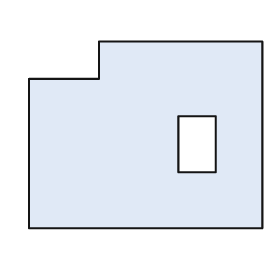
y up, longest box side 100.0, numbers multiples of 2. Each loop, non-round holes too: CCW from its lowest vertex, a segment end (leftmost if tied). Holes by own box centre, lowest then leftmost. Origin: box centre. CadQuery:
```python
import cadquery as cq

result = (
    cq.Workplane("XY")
    .moveTo(-50.0, -40.0)
    .lineTo(50.0, -40.0)
    .lineTo(50.0, 40.0)
    .lineTo(-20.0, 40.0)
    .lineTo(-20.0, 24.0)
    .lineTo(-50.0, 24.0)
    .close()
    .moveTo(14.0, -16.0)
    .lineTo(30.0, -16.0)
    .lineTo(30.0, 8.0)
    .lineTo(14.0, 8.0)
    .close()
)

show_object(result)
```